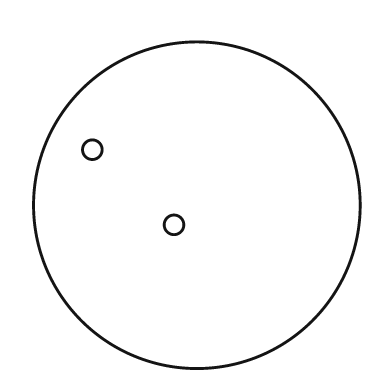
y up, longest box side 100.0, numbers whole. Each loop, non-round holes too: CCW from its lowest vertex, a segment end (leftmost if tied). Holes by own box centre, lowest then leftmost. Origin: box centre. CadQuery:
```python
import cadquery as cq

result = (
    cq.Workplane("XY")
    .moveTo(0.0, 0.0)
    .circle(50.0)
    .moveTo(-7.0, -6.0)
    .circle(3.0)
    .moveTo(-32.0, 17.0)
    .circle(3.0)
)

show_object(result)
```